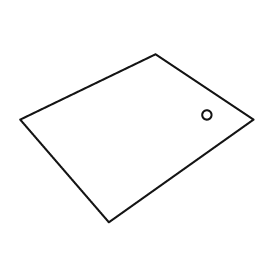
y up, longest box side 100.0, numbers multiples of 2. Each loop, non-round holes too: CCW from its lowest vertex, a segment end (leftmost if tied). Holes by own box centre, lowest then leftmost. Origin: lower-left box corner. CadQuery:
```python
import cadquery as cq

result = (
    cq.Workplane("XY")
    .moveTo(38.0, 0.0)
    .lineTo(100.0, 44.0)
    .lineTo(58.0, 72.0)
    .lineTo(0.0, 44.0)
    .close()
    .moveTo(80.0, 46.0)
    .circle(2.0)
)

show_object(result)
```